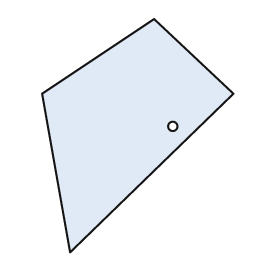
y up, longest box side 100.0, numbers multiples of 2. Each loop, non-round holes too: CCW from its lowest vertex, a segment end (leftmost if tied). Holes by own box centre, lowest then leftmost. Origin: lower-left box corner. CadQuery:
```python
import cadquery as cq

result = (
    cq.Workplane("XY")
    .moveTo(12.0, 0.0)
    .lineTo(82.0, 68.0)
    .lineTo(48.0, 100.0)
    .lineTo(0.0, 68.0)
    .close()
    .moveTo(56.0, 54.0)
    .circle(2.0)
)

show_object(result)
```